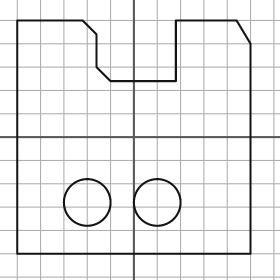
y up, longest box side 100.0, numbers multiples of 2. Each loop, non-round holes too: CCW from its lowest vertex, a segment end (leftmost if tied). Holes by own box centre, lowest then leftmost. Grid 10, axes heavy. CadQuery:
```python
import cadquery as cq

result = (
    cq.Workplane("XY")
    .moveTo(-50.0, -50.0)
    .lineTo(50.0, -50.0)
    .lineTo(50.0, 40.0)
    .lineTo(44.0, 50.0)
    .lineTo(18.0, 50.0)
    .lineTo(18.0, 24.0)
    .lineTo(-10.0, 24.0)
    .lineTo(-16.0, 30.0)
    .lineTo(-16.0, 44.0)
    .lineTo(-22.0, 50.0)
    .lineTo(-50.0, 50.0)
    .close()
    .moveTo(-20.0, -28.0)
    .circle(10.0)
    .moveTo(10.0, -28.0)
    .circle(10.0)
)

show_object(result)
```